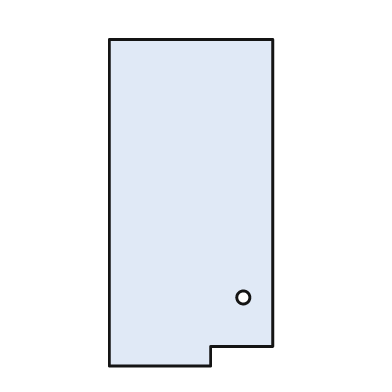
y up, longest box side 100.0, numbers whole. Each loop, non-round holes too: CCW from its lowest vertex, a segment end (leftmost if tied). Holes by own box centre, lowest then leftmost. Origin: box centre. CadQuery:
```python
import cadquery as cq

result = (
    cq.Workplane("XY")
    .moveTo(-25.0, -50.0)
    .lineTo(6.0, -50.0)
    .lineTo(6.0, -44.0)
    .lineTo(25.0, -44.0)
    .lineTo(25.0, 50.0)
    .lineTo(-25.0, 50.0)
    .close()
    .moveTo(16.0, -29.0)
    .circle(2.0)
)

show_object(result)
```